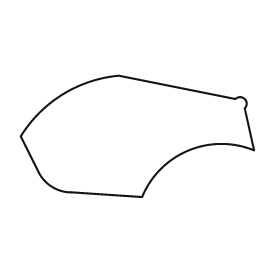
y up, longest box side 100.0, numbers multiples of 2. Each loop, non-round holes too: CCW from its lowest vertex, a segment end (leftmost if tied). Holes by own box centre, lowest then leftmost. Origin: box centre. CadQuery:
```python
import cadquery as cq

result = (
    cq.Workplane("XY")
    .moveTo(2.0, -26.0)
    .threePointArc((22.0, -6.0), (50.0, -6.0))
    .lineTo(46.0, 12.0)
    .threePointArc((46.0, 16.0), (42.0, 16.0))
    .lineTo(-8.0, 26.0)
    .threePointArc((-32.0, 18.0), (-50.0, 0.0))
    .lineTo(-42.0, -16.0)
    .threePointArc((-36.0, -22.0), (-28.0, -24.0))
    .close()
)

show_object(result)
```